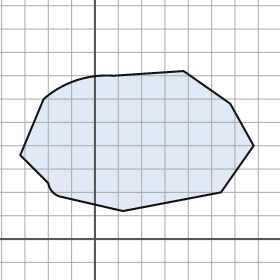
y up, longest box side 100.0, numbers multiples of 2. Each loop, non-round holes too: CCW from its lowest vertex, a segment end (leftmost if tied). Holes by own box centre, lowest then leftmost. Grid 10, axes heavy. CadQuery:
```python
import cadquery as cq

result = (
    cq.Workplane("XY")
    .moveTo(12.0, 12.0)
    .lineTo(54.0, 20.0)
    .lineTo(68.0, 40.0)
    .lineTo(58.0, 58.0)
    .lineTo(38.0, 72.0)
    .lineTo(8.0, 70.0)
    .threePointArc((-8.0, 68.0), (-22.0, 60.0))
    .lineTo(-32.0, 36.0)
    .lineTo(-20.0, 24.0)
    .threePointArc((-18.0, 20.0), (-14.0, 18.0))
    .close()
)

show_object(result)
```